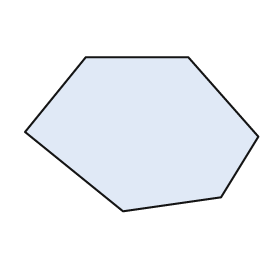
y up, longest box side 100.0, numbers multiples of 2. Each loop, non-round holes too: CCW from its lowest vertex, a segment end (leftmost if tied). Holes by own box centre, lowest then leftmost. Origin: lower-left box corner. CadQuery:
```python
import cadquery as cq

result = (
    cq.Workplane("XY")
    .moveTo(42.0, 0.0)
    .lineTo(84.0, 6.0)
    .lineTo(100.0, 32.0)
    .lineTo(70.0, 66.0)
    .lineTo(26.0, 66.0)
    .lineTo(0.0, 34.0)
    .close()
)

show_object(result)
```